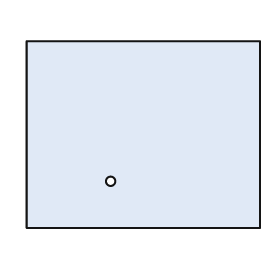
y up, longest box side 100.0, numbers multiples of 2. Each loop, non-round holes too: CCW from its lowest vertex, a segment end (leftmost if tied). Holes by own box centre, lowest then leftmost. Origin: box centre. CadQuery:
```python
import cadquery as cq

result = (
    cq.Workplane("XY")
    .moveTo(-50.0, -40.0)
    .lineTo(50.0, -40.0)
    .lineTo(50.0, 40.0)
    .lineTo(-50.0, 40.0)
    .close()
    .moveTo(-14.0, -20.0)
    .circle(2.0)
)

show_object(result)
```